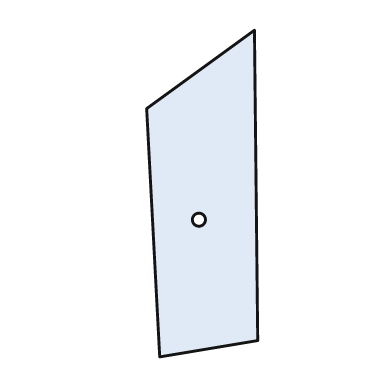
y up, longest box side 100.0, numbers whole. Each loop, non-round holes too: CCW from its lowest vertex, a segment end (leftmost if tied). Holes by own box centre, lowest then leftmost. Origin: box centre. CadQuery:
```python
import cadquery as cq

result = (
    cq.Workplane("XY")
    .moveTo(-13.0, -50.0)
    .lineTo(17.0, -45.0)
    .lineTo(16.0, 50.0)
    .lineTo(-17.0, 26.0)
    .close()
    .moveTo(-1.0, -8.0)
    .circle(2.0)
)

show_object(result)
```